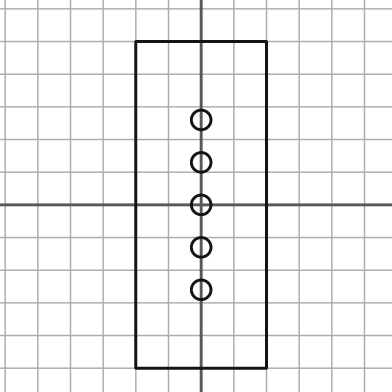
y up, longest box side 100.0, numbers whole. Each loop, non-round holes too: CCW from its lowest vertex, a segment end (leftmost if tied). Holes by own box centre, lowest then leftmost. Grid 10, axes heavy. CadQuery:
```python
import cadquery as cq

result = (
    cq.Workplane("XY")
    .moveTo(-20.0, -50.0)
    .lineTo(20.0, -50.0)
    .lineTo(20.0, 50.0)
    .lineTo(-20.0, 50.0)
    .close()
    .moveTo(0.0, -26.0)
    .circle(3.0)
    .moveTo(0.0, -13.0)
    .circle(3.0)
    .moveTo(0.0, 0.0)
    .circle(3.0)
    .moveTo(0.0, 13.0)
    .circle(3.0)
    .moveTo(0.0, 26.0)
    .circle(3.0)
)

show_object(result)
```